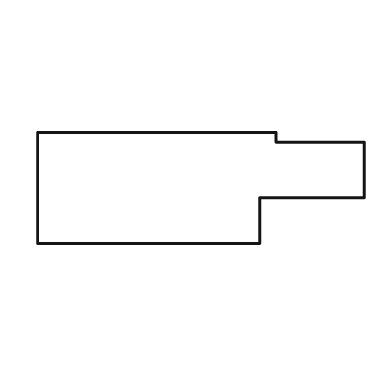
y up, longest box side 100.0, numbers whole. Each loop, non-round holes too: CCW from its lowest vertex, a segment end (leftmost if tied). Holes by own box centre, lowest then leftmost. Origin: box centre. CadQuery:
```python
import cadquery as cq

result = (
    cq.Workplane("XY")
    .moveTo(-50.0, -17.0)
    .lineTo(18.0, -17.0)
    .lineTo(18.0, -3.0)
    .lineTo(50.0, -3.0)
    .lineTo(50.0, 14.0)
    .lineTo(23.0, 14.0)
    .lineTo(23.0, 17.0)
    .lineTo(-50.0, 17.0)
    .close()
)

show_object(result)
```